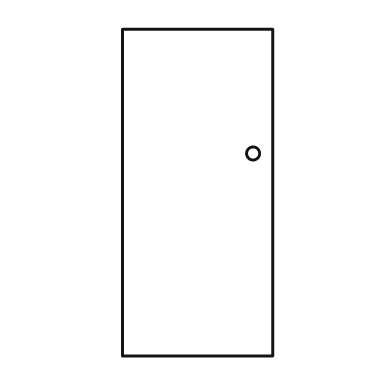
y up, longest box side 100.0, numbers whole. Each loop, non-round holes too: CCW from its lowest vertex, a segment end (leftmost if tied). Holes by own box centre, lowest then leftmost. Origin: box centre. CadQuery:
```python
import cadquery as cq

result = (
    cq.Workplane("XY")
    .moveTo(-23.0, -50.0)
    .lineTo(23.0, -50.0)
    .lineTo(23.0, 50.0)
    .lineTo(-23.0, 50.0)
    .close()
    .moveTo(17.0, 12.0)
    .circle(2.0)
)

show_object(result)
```